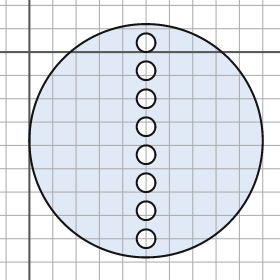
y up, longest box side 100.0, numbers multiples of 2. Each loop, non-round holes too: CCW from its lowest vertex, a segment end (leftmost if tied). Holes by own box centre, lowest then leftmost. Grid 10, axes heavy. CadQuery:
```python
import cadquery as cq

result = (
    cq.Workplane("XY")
    .moveTo(50.0, -38.0)
    .circle(50.0)
    .moveTo(50.0, -80.0)
    .circle(4.0)
    .moveTo(50.0, -68.0)
    .circle(4.0)
    .moveTo(50.0, -56.0)
    .circle(4.0)
    .moveTo(50.0, -44.0)
    .circle(4.0)
    .moveTo(50.0, -32.0)
    .circle(4.0)
    .moveTo(50.0, -20.0)
    .circle(4.0)
    .moveTo(50.0, -8.0)
    .circle(4.0)
    .moveTo(50.0, 4.0)
    .circle(4.0)
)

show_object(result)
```